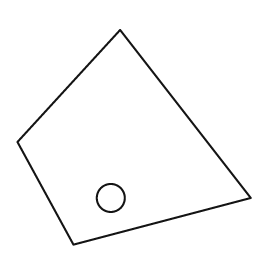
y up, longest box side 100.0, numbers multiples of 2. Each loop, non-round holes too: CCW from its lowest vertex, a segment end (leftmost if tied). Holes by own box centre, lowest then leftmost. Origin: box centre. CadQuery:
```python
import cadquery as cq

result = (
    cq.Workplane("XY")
    .moveTo(-26.0, -46.0)
    .lineTo(50.0, -26.0)
    .lineTo(-6.0, 46.0)
    .lineTo(-50.0, -2.0)
    .close()
    .moveTo(-10.0, -26.0)
    .circle(6.0)
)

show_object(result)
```